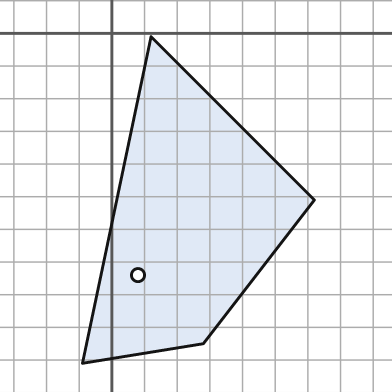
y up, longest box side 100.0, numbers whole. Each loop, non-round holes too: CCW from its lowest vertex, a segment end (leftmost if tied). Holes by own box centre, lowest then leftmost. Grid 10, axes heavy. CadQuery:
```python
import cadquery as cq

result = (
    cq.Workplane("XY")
    .moveTo(-9.0, -101.0)
    .lineTo(28.0, -95.0)
    .lineTo(62.0, -51.0)
    .lineTo(12.0, -1.0)
    .close()
    .moveTo(8.0, -74.0)
    .circle(2.0)
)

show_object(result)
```